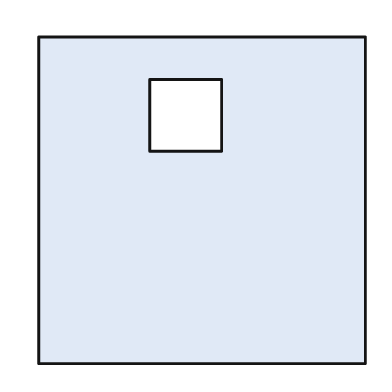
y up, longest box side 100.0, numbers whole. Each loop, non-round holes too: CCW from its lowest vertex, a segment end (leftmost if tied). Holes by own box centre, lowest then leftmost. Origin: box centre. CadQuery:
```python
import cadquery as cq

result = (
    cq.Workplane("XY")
    .moveTo(-50.0, -50.0)
    .lineTo(50.0, -50.0)
    .lineTo(50.0, 50.0)
    .lineTo(-50.0, 50.0)
    .close()
    .moveTo(-16.0, 15.0)
    .lineTo(6.0, 15.0)
    .lineTo(6.0, 37.0)
    .lineTo(-16.0, 37.0)
    .close()
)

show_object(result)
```